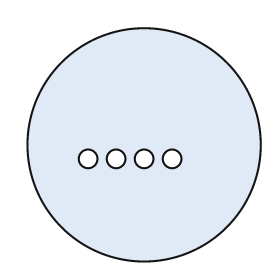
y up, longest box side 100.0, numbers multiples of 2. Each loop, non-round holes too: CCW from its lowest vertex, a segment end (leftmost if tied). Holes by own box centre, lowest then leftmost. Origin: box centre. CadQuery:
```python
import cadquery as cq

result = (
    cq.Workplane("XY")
    .moveTo(0.0, 0.0)
    .circle(50.0)
    .moveTo(-24.0, -6.0)
    .circle(4.0)
    .moveTo(-12.0, -6.0)
    .circle(4.0)
    .moveTo(0.0, -6.0)
    .circle(4.0)
    .moveTo(12.0, -6.0)
    .circle(4.0)
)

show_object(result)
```